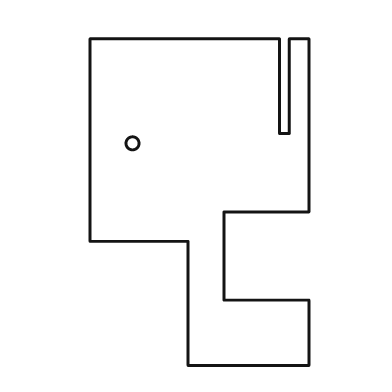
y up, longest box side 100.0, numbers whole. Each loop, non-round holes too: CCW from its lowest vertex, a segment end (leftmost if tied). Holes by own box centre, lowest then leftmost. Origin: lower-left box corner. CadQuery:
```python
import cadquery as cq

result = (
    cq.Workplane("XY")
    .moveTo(30.0, 0.0)
    .lineTo(67.0, 0.0)
    .lineTo(67.0, 20.0)
    .lineTo(41.0, 20.0)
    .lineTo(41.0, 47.0)
    .lineTo(67.0, 47.0)
    .lineTo(67.0, 100.0)
    .lineTo(61.0, 100.0)
    .lineTo(61.0, 71.0)
    .lineTo(58.0, 71.0)
    .lineTo(58.0, 100.0)
    .lineTo(0.0, 100.0)
    .lineTo(0.0, 38.0)
    .lineTo(30.0, 38.0)
    .close()
    .moveTo(13.0, 68.0)
    .circle(2.0)
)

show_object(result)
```